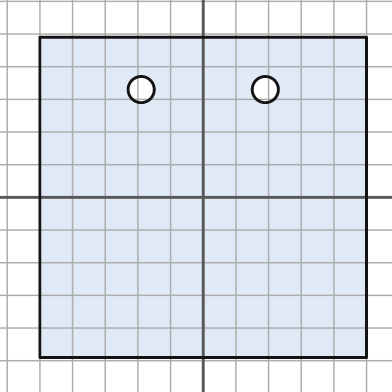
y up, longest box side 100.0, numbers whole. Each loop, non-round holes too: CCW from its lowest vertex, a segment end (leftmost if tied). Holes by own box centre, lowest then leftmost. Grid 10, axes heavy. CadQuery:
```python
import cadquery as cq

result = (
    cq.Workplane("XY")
    .moveTo(-50.0, -49.0)
    .lineTo(50.0, -49.0)
    .lineTo(50.0, 49.0)
    .lineTo(-50.0, 49.0)
    .close()
    .moveTo(-19.0, 33.0)
    .circle(4.0)
    .moveTo(19.0, 33.0)
    .circle(4.0)
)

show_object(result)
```